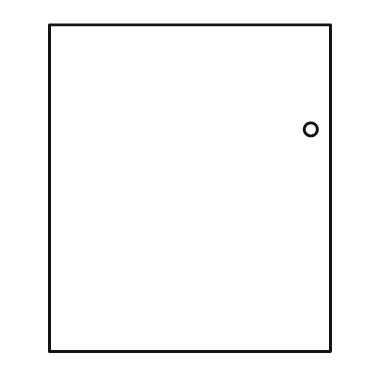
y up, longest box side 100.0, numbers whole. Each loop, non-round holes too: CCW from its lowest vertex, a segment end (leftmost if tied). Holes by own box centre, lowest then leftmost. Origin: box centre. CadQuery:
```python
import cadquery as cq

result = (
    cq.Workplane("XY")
    .moveTo(-43.0, -50.0)
    .lineTo(43.0, -50.0)
    .lineTo(43.0, 50.0)
    .lineTo(-43.0, 50.0)
    .close()
    .moveTo(37.0, 18.0)
    .circle(2.0)
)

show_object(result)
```